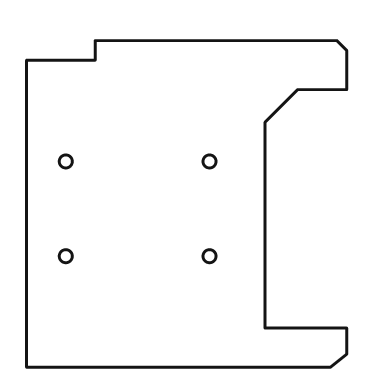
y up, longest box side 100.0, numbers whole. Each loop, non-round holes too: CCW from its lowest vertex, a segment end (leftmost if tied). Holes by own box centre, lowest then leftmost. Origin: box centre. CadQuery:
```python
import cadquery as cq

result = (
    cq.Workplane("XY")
    .moveTo(-49.0, -50.0)
    .lineTo(44.0, -50.0)
    .lineTo(49.0, -46.0)
    .lineTo(49.0, -38.0)
    .lineTo(24.0, -38.0)
    .lineTo(24.0, 25.0)
    .lineTo(34.0, 35.0)
    .lineTo(49.0, 35.0)
    .lineTo(49.0, 47.0)
    .lineTo(46.0, 50.0)
    .lineTo(-28.0, 50.0)
    .lineTo(-28.0, 44.0)
    .lineTo(-49.0, 44.0)
    .close()
    .moveTo(-37.0, -16.0)
    .circle(2.0)
    .moveTo(7.0, -16.0)
    .circle(2.0)
    .moveTo(-37.0, 13.0)
    .circle(2.0)
    .moveTo(7.0, 13.0)
    .circle(2.0)
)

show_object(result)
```